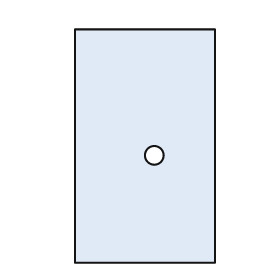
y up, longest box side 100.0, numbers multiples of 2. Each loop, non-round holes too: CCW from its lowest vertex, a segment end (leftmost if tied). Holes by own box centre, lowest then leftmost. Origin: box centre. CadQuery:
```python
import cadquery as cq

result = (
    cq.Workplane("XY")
    .moveTo(-30.0, -50.0)
    .lineTo(30.0, -50.0)
    .lineTo(30.0, 50.0)
    .lineTo(-30.0, 50.0)
    .close()
    .moveTo(4.0, -4.0)
    .circle(4.0)
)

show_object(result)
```